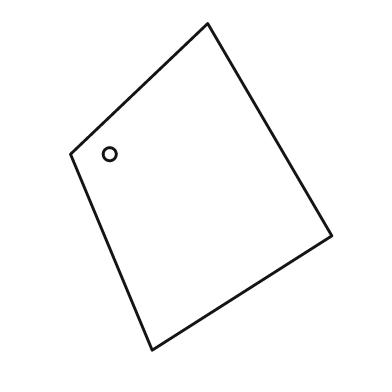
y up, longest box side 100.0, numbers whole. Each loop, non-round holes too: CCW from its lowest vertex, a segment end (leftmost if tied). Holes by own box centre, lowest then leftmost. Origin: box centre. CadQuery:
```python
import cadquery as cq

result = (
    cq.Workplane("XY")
    .moveTo(-15.0, -50.0)
    .lineTo(40.0, -15.0)
    .lineTo(2.0, 50.0)
    .lineTo(-40.0, 10.0)
    .close()
    .moveTo(-28.0, 10.0)
    .circle(2.0)
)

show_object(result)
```